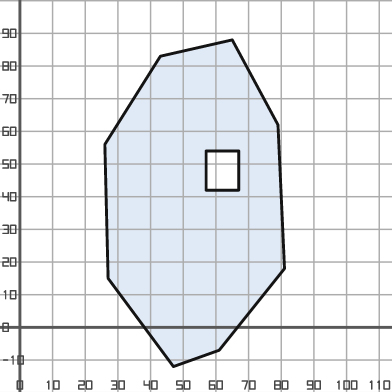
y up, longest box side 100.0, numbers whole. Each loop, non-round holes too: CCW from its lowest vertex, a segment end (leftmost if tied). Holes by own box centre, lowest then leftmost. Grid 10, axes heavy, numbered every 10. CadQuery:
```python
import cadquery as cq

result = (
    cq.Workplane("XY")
    .moveTo(47.0, -12.0)
    .lineTo(61.0, -7.0)
    .lineTo(81.0, 18.0)
    .lineTo(79.0, 62.0)
    .lineTo(65.0, 88.0)
    .lineTo(43.0, 83.0)
    .lineTo(26.0, 56.0)
    .lineTo(27.0, 15.0)
    .close()
    .moveTo(57.0, 42.0)
    .lineTo(67.0, 42.0)
    .lineTo(67.0, 54.0)
    .lineTo(57.0, 54.0)
    .close()
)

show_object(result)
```